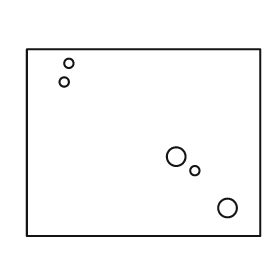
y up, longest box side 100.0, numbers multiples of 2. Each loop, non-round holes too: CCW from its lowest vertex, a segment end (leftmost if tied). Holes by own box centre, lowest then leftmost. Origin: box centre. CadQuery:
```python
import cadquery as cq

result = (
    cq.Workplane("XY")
    .moveTo(-50.0, -40.0)
    .lineTo(50.0, -40.0)
    .lineTo(50.0, 40.0)
    .lineTo(-50.0, 40.0)
    .close()
    .moveTo(36.0, -28.0)
    .circle(4.0)
    .moveTo(22.0, -12.0)
    .circle(2.0)
    .moveTo(14.0, -6.0)
    .circle(4.0)
    .moveTo(-34.0, 26.0)
    .circle(2.0)
    .moveTo(-32.0, 34.0)
    .circle(2.0)
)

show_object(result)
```